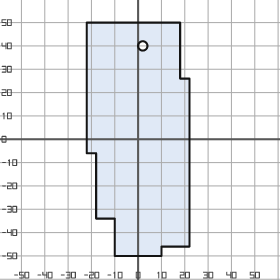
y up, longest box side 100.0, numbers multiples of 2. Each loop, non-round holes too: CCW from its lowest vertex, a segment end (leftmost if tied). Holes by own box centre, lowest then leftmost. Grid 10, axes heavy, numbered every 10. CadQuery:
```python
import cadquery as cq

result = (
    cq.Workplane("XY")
    .moveTo(-10.0, -50.0)
    .lineTo(10.0, -50.0)
    .lineTo(10.0, -46.0)
    .lineTo(22.0, -46.0)
    .lineTo(22.0, 26.0)
    .lineTo(18.0, 26.0)
    .lineTo(18.0, 50.0)
    .lineTo(-22.0, 50.0)
    .lineTo(-22.0, -6.0)
    .lineTo(-18.0, -6.0)
    .lineTo(-18.0, -34.0)
    .lineTo(-10.0, -34.0)
    .close()
    .moveTo(2.0, 40.0)
    .circle(2.0)
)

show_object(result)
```